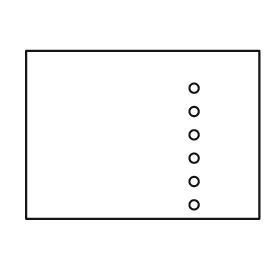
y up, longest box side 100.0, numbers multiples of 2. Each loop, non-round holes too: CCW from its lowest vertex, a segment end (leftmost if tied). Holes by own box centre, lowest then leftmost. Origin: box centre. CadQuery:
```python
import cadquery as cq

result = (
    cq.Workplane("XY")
    .moveTo(-50.0, -36.0)
    .lineTo(50.0, -36.0)
    .lineTo(50.0, 36.0)
    .lineTo(-50.0, 36.0)
    .close()
    .moveTo(22.0, -30.0)
    .circle(2.0)
    .moveTo(22.0, -20.0)
    .circle(2.0)
    .moveTo(22.0, -10.0)
    .circle(2.0)
    .moveTo(22.0, 0.0)
    .circle(2.0)
    .moveTo(22.0, 10.0)
    .circle(2.0)
    .moveTo(22.0, 20.0)
    .circle(2.0)
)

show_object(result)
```